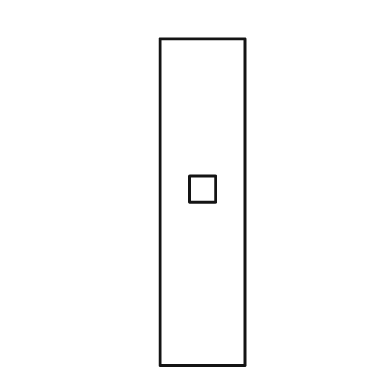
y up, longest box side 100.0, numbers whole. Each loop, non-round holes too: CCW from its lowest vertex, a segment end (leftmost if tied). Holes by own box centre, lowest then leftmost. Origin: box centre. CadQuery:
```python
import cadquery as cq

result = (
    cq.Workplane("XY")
    .moveTo(-13.0, -50.0)
    .lineTo(13.0, -50.0)
    .lineTo(13.0, 50.0)
    .lineTo(-13.0, 50.0)
    .close()
    .moveTo(-4.0, 0.0)
    .lineTo(4.0, 0.0)
    .lineTo(4.0, 8.0)
    .lineTo(-4.0, 8.0)
    .close()
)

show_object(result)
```